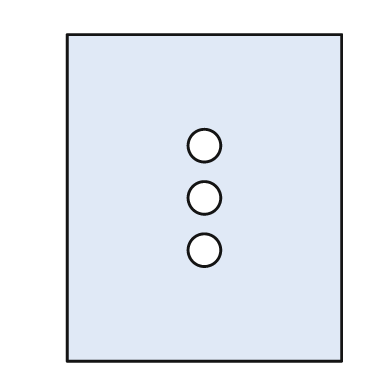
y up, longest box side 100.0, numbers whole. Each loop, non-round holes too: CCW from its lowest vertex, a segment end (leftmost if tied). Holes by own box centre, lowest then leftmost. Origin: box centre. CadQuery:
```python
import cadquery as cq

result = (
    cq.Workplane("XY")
    .moveTo(-42.0, -50.0)
    .lineTo(42.0, -50.0)
    .lineTo(42.0, 50.0)
    .lineTo(-42.0, 50.0)
    .close()
    .moveTo(0.0, -16.0)
    .circle(5.0)
    .moveTo(0.0, 0.0)
    .circle(5.0)
    .moveTo(0.0, 16.0)
    .circle(5.0)
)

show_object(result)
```